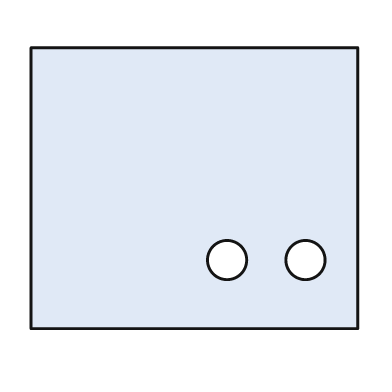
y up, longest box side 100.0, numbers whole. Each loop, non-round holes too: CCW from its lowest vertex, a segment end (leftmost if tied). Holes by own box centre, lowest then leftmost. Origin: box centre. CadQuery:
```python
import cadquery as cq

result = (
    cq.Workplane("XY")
    .moveTo(-50.0, -43.0)
    .lineTo(50.0, -43.0)
    .lineTo(50.0, 43.0)
    .lineTo(-50.0, 43.0)
    .close()
    .moveTo(10.0, -22.0)
    .circle(6.0)
    .moveTo(34.0, -22.0)
    .circle(6.0)
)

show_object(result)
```